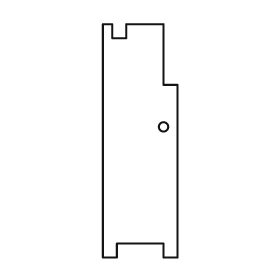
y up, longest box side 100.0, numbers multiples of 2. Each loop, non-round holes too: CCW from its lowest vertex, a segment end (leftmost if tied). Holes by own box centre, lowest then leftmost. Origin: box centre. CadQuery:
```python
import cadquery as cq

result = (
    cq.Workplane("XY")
    .moveTo(-16.0, -50.0)
    .lineTo(-10.0, -50.0)
    .lineTo(-10.0, -44.0)
    .lineTo(10.0, -44.0)
    .lineTo(10.0, -50.0)
    .lineTo(16.0, -50.0)
    .lineTo(16.0, 24.0)
    .lineTo(10.0, 24.0)
    .lineTo(10.0, 50.0)
    .lineTo(-6.0, 50.0)
    .lineTo(-6.0, 44.0)
    .lineTo(-12.0, 44.0)
    .lineTo(-12.0, 50.0)
    .lineTo(-16.0, 50.0)
    .close()
    .moveTo(10.0, 6.0)
    .circle(2.0)
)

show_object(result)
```